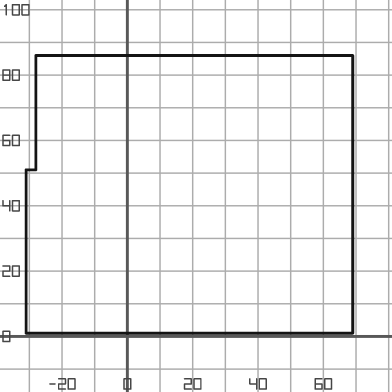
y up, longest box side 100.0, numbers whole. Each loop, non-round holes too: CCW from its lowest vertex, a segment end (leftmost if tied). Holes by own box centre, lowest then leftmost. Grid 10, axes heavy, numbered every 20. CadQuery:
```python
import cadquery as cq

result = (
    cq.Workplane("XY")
    .moveTo(-31.0, 1.0)
    .lineTo(69.0, 1.0)
    .lineTo(69.0, 86.0)
    .lineTo(-28.0, 86.0)
    .lineTo(-28.0, 51.0)
    .lineTo(-31.0, 51.0)
    .close()
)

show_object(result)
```